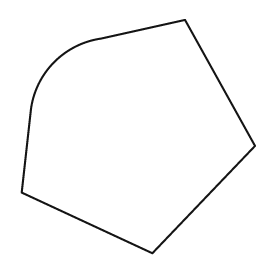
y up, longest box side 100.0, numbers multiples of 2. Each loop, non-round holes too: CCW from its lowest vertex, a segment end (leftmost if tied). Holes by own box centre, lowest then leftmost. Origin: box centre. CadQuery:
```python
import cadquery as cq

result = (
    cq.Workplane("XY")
    .moveTo(6.0, -50.0)
    .lineTo(50.0, -4.0)
    .lineTo(20.0, 50.0)
    .lineTo(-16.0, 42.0)
    .threePointArc((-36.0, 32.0), (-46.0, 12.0))
    .lineTo(-50.0, -24.0)
    .close()
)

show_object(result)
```